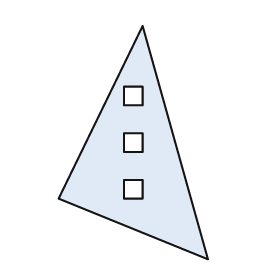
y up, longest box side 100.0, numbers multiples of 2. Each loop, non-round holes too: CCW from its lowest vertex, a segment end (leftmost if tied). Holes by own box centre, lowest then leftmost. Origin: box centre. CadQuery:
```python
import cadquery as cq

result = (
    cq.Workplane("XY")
    .moveTo(32.0, -50.0)
    .lineTo(4.0, 50.0)
    .lineTo(-32.0, -24.0)
    .close()
    .moveTo(-4.0, -24.0)
    .lineTo(4.0, -24.0)
    .lineTo(4.0, -16.0)
    .lineTo(-4.0, -16.0)
    .close()
    .moveTo(-4.0, -4.0)
    .lineTo(4.0, -4.0)
    .lineTo(4.0, 4.0)
    .lineTo(-4.0, 4.0)
    .close()
    .moveTo(-4.0, 16.0)
    .lineTo(4.0, 16.0)
    .lineTo(4.0, 24.0)
    .lineTo(-4.0, 24.0)
    .close()
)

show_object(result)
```